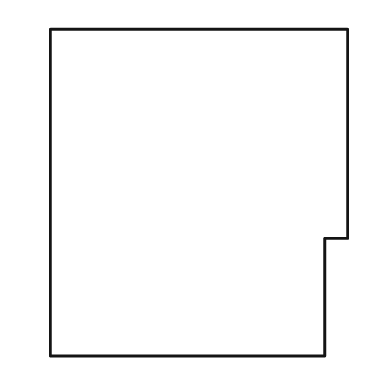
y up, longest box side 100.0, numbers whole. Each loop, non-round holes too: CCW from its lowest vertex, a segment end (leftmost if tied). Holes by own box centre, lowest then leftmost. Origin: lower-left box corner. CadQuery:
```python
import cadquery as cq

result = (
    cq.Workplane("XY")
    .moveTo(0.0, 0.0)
    .lineTo(84.0, 0.0)
    .lineTo(84.0, 36.0)
    .lineTo(91.0, 36.0)
    .lineTo(91.0, 100.0)
    .lineTo(0.0, 100.0)
    .close()
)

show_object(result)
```